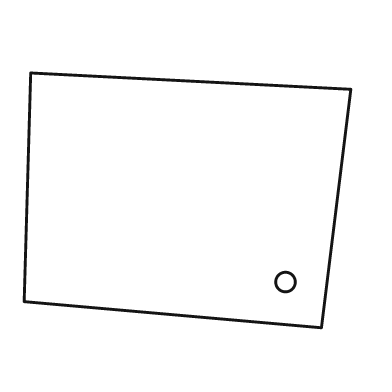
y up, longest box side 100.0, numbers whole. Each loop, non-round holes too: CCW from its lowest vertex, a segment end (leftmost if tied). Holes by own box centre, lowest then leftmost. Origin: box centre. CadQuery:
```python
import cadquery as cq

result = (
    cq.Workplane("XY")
    .moveTo(41.0, -39.0)
    .lineTo(50.0, 34.0)
    .lineTo(-48.0, 39.0)
    .lineTo(-50.0, -31.0)
    .close()
    .moveTo(30.0, -25.0)
    .circle(3.0)
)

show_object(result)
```